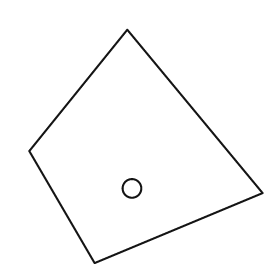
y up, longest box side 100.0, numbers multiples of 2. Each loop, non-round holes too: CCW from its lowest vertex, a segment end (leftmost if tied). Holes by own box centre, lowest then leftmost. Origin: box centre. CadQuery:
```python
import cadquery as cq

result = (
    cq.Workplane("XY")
    .moveTo(-22.0, -50.0)
    .lineTo(50.0, -20.0)
    .lineTo(-8.0, 50.0)
    .lineTo(-50.0, -2.0)
    .close()
    .moveTo(-6.0, -18.0)
    .circle(4.0)
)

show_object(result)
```